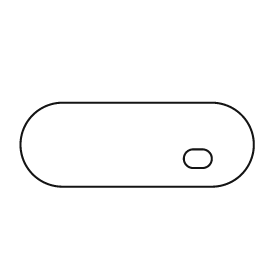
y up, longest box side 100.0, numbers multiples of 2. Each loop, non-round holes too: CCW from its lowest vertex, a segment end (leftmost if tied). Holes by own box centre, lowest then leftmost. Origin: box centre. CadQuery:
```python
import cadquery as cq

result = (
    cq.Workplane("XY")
    .moveTo(-32.0, -18.0)
    .lineTo(32.0, -18.0)
    .threePointArc((50.0, 0.0), (32.0, 18.0))
    .lineTo(-32.0, 18.0)
    .threePointArc((-50.0, 0.0), (-32.0, -18.0))
    .close()
    .moveTo(24.0, -10.0)
    .lineTo(28.0, -10.0)
    .threePointArc((32.0, -6.0), (28.0, -2.0))
    .lineTo(24.0, -2.0)
    .threePointArc((20.0, -6.0), (24.0, -10.0))
    .close()
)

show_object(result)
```